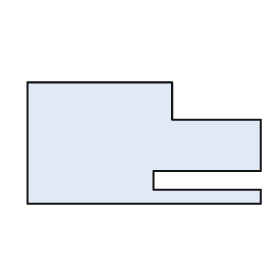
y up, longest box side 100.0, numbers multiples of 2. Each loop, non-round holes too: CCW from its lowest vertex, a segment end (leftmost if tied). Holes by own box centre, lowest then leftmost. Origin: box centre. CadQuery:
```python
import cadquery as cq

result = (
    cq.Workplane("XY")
    .moveTo(-50.0, -26.0)
    .lineTo(50.0, -26.0)
    .lineTo(50.0, -20.0)
    .lineTo(4.0, -20.0)
    .lineTo(4.0, -12.0)
    .lineTo(50.0, -12.0)
    .lineTo(50.0, 10.0)
    .lineTo(12.0, 10.0)
    .lineTo(12.0, 26.0)
    .lineTo(-50.0, 26.0)
    .close()
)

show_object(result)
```